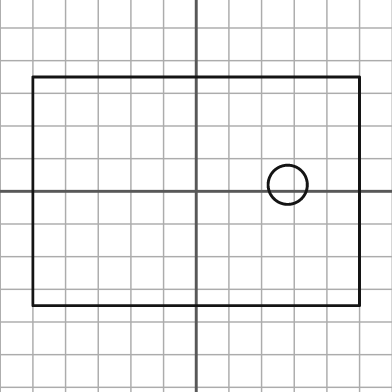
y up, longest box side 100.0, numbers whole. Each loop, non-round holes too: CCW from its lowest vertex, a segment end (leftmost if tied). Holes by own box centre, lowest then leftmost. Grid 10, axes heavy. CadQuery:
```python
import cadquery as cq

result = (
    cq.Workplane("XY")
    .moveTo(-50.0, -35.0)
    .lineTo(50.0, -35.0)
    .lineTo(50.0, 35.0)
    .lineTo(-50.0, 35.0)
    .close()
    .moveTo(28.0, 2.0)
    .circle(6.0)
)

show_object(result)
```